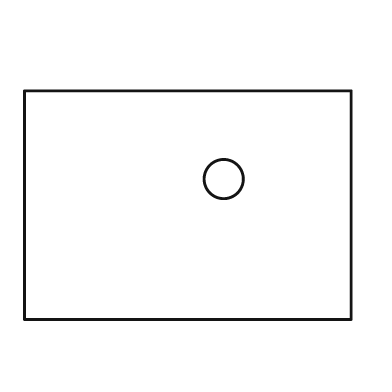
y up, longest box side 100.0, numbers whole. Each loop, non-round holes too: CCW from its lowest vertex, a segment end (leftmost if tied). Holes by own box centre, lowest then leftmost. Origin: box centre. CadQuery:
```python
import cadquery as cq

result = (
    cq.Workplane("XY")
    .moveTo(-50.0, -35.0)
    .lineTo(50.0, -35.0)
    .lineTo(50.0, 35.0)
    .lineTo(-50.0, 35.0)
    .close()
    .moveTo(11.0, 8.0)
    .circle(6.0)
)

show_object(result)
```